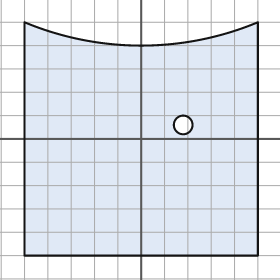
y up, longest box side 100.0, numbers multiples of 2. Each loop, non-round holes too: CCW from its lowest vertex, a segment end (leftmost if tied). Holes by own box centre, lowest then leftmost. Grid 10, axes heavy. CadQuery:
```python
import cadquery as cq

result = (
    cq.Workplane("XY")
    .moveTo(-50.0, -50.0)
    .lineTo(50.0, -50.0)
    .lineTo(50.0, 50.0)
    .threePointArc((0.0, 40.0), (-50.0, 50.0))
    .close()
    .moveTo(18.0, 6.0)
    .circle(4.0)
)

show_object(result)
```